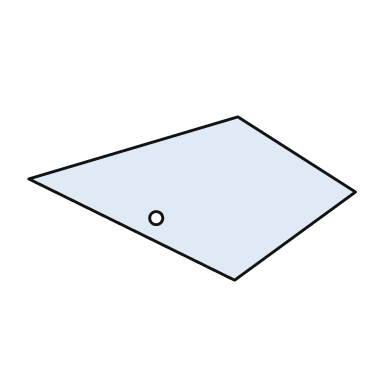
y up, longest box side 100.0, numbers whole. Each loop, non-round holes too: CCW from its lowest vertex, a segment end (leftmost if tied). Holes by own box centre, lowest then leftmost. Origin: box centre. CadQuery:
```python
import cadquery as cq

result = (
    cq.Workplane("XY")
    .moveTo(13.0, -25.0)
    .lineTo(50.0, 2.0)
    .lineTo(14.0, 25.0)
    .lineTo(-50.0, 6.0)
    .close()
    .moveTo(-11.0, -6.0)
    .circle(2.0)
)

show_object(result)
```